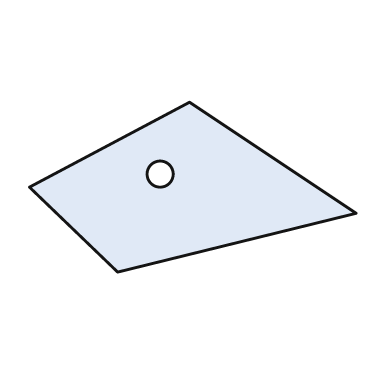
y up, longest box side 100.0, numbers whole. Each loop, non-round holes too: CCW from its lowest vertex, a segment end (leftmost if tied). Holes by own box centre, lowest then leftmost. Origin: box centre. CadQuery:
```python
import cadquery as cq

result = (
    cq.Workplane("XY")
    .moveTo(-23.0, -26.0)
    .lineTo(50.0, -8.0)
    .lineTo(-1.0, 26.0)
    .lineTo(-50.0, 0.0)
    .close()
    .moveTo(-10.0, 4.0)
    .circle(4.0)
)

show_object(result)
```